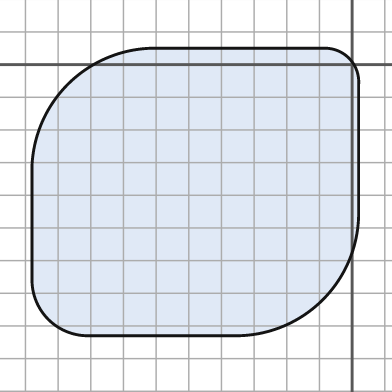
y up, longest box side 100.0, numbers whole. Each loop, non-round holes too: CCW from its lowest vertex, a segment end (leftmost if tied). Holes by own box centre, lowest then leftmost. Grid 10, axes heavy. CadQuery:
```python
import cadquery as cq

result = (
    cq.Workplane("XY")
    .moveTo(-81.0, -83.0)
    .lineTo(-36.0, -83.0)
    .threePointArc((-9.0, -72.0), (2.0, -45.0))
    .lineTo(2.0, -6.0)
    .threePointArc((-1.0, 2.0), (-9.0, 5.0))
    .lineTo(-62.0, 5.0)
    .threePointArc((-87.0, -6.0), (-98.0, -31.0))
    .lineTo(-98.0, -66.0)
    .threePointArc((-93.0, -78.0), (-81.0, -83.0))
    .close()
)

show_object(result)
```